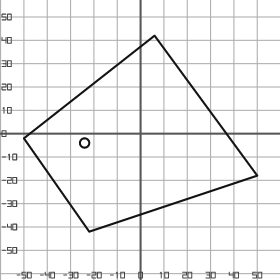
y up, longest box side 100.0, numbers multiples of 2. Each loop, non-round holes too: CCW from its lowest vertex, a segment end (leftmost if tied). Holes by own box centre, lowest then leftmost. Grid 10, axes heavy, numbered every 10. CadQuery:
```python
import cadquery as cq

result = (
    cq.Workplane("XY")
    .moveTo(-22.0, -42.0)
    .lineTo(50.0, -18.0)
    .lineTo(6.0, 42.0)
    .lineTo(-50.0, -2.0)
    .close()
    .moveTo(-24.0, -4.0)
    .circle(2.0)
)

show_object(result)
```